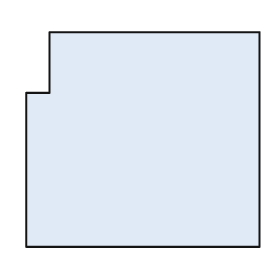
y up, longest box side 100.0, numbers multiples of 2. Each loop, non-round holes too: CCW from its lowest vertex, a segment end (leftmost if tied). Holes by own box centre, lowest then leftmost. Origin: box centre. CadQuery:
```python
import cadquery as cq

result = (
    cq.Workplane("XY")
    .moveTo(-50.0, -46.0)
    .lineTo(50.0, -46.0)
    .lineTo(50.0, 46.0)
    .lineTo(-40.0, 46.0)
    .lineTo(-40.0, 20.0)
    .lineTo(-50.0, 20.0)
    .close()
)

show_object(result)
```